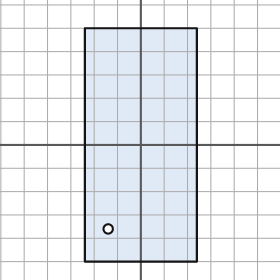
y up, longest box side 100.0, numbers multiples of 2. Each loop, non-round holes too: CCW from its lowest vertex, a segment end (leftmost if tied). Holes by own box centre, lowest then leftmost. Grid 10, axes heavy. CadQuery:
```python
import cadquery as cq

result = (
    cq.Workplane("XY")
    .moveTo(-24.0, -50.0)
    .lineTo(24.0, -50.0)
    .lineTo(24.0, 50.0)
    .lineTo(-24.0, 50.0)
    .close()
    .moveTo(-14.0, -36.0)
    .circle(2.0)
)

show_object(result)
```